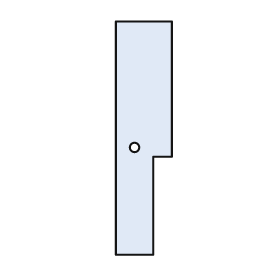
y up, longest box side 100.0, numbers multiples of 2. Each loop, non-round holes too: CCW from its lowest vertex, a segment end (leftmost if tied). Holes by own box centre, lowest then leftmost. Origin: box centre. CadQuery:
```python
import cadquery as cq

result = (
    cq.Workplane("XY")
    .moveTo(-12.0, -50.0)
    .lineTo(4.0, -50.0)
    .lineTo(4.0, -8.0)
    .lineTo(12.0, -8.0)
    .lineTo(12.0, 50.0)
    .lineTo(-12.0, 50.0)
    .close()
    .moveTo(-4.0, -4.0)
    .circle(2.0)
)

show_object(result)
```